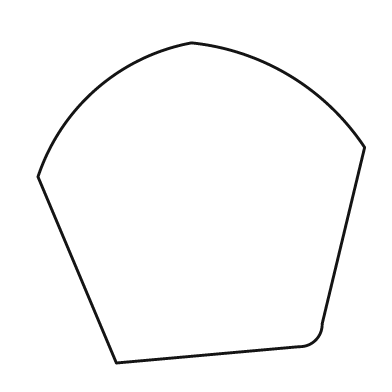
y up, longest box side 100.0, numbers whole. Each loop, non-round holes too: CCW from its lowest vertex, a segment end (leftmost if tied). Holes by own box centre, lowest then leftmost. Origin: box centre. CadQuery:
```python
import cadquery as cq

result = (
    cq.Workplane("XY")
    .moveTo(-26.0, -49.0)
    .lineTo(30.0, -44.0)
    .threePointArc((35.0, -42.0), (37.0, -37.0))
    .lineTo(50.0, 17.0)
    .threePointArc((27.0, 39.0), (-3.0, 49.0))
    .threePointArc((-32.0, 35.0), (-50.0, 8.0))
    .close()
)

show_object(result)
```